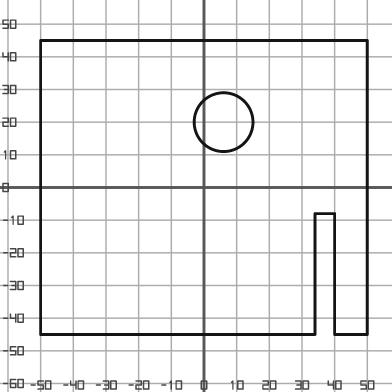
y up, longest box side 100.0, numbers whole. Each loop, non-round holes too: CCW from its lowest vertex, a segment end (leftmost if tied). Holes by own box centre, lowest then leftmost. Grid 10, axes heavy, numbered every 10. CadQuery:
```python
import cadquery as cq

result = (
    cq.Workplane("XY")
    .moveTo(-50.0, -45.0)
    .lineTo(34.0, -45.0)
    .lineTo(34.0, -8.0)
    .lineTo(40.0, -8.0)
    .lineTo(40.0, -45.0)
    .lineTo(50.0, -45.0)
    .lineTo(50.0, 45.0)
    .lineTo(-50.0, 45.0)
    .close()
    .moveTo(6.0, 20.0)
    .circle(9.0)
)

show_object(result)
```